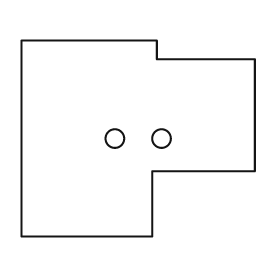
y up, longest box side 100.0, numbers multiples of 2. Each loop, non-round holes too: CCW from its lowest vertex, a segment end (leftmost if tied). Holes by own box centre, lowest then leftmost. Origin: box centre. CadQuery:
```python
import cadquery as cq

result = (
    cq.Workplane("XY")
    .moveTo(-50.0, -42.0)
    .lineTo(6.0, -42.0)
    .lineTo(6.0, -14.0)
    .lineTo(50.0, -14.0)
    .lineTo(50.0, 34.0)
    .lineTo(8.0, 34.0)
    .lineTo(8.0, 42.0)
    .lineTo(-50.0, 42.0)
    .close()
    .moveTo(-10.0, 0.0)
    .circle(4.0)
    .moveTo(10.0, 0.0)
    .circle(4.0)
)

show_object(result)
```